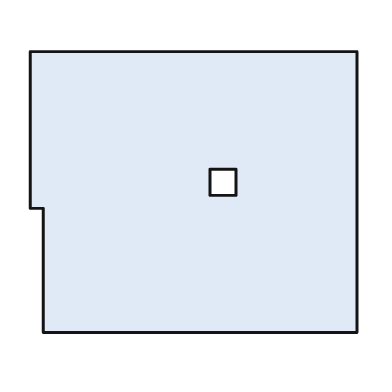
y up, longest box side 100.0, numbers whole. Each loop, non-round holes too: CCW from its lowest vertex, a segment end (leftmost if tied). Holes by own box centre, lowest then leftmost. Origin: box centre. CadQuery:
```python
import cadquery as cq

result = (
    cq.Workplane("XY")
    .moveTo(-46.0, -43.0)
    .lineTo(50.0, -43.0)
    .lineTo(50.0, 43.0)
    .lineTo(-50.0, 43.0)
    .lineTo(-50.0, -5.0)
    .lineTo(-46.0, -5.0)
    .close()
    .moveTo(5.0, -1.0)
    .lineTo(13.0, -1.0)
    .lineTo(13.0, 7.0)
    .lineTo(5.0, 7.0)
    .close()
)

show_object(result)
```